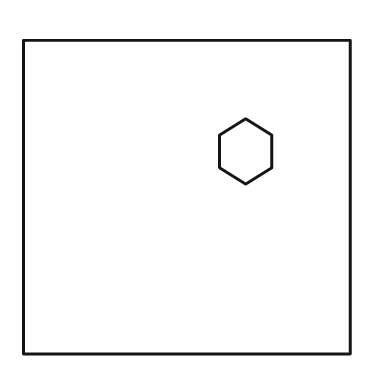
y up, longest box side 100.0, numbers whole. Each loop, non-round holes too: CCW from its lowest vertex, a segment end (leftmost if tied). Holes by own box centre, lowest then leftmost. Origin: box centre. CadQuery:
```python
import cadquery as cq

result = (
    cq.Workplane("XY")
    .moveTo(-50.0, -48.0)
    .lineTo(50.0, -48.0)
    .lineTo(50.0, 48.0)
    .lineTo(-50.0, 48.0)
    .close()
    .moveTo(18.0, 4.0)
    .lineTo(26.0, 9.0)
    .lineTo(26.0, 19.0)
    .lineTo(18.0, 24.0)
    .lineTo(10.0, 19.0)
    .lineTo(10.0, 9.0)
    .close()
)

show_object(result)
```